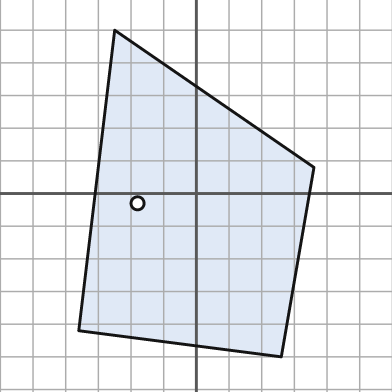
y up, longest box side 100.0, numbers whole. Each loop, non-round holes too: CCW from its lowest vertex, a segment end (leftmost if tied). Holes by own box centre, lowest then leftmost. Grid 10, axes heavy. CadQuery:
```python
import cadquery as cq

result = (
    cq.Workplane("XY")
    .moveTo(26.0, -50.0)
    .lineTo(36.0, 8.0)
    .lineTo(-25.0, 50.0)
    .lineTo(-36.0, -42.0)
    .close()
    .moveTo(-18.0, -3.0)
    .circle(2.0)
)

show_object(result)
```